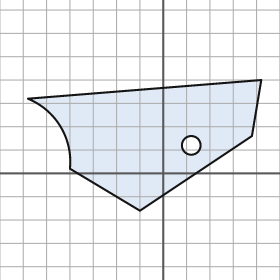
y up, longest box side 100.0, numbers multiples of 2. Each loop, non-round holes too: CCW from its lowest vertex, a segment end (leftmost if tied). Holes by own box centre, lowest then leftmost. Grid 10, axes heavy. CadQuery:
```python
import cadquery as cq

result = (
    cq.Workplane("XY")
    .moveTo(-10.0, -16.0)
    .lineTo(38.0, 16.0)
    .lineTo(42.0, 40.0)
    .lineTo(-58.0, 32.0)
    .threePointArc((-44.0, 20.0), (-40.0, 2.0))
    .close()
    .moveTo(12.0, 12.0)
    .circle(4.0)
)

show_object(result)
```